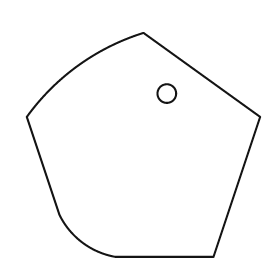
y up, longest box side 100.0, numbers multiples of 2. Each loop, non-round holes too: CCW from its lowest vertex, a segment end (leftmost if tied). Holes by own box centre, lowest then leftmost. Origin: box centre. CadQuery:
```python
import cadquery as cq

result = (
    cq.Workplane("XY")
    .moveTo(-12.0, -48.0)
    .lineTo(30.0, -48.0)
    .lineTo(50.0, 12.0)
    .lineTo(0.0, 48.0)
    .threePointArc((-28.0, 34.0), (-50.0, 12.0))
    .lineTo(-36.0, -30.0)
    .threePointArc((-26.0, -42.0), (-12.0, -48.0))
    .close()
    .moveTo(10.0, 22.0)
    .circle(4.0)
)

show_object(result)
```